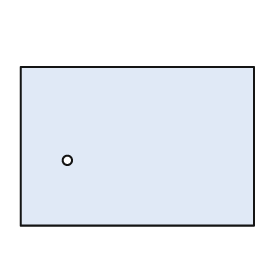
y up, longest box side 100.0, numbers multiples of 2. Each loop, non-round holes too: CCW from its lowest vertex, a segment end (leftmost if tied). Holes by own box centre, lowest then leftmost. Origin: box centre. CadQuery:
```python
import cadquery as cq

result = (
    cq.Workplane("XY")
    .moveTo(-50.0, -34.0)
    .lineTo(50.0, -34.0)
    .lineTo(50.0, 34.0)
    .lineTo(-50.0, 34.0)
    .close()
    .moveTo(-30.0, -6.0)
    .circle(2.0)
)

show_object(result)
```